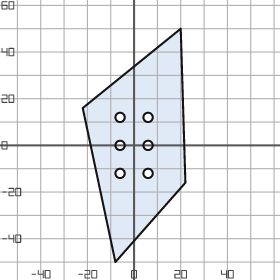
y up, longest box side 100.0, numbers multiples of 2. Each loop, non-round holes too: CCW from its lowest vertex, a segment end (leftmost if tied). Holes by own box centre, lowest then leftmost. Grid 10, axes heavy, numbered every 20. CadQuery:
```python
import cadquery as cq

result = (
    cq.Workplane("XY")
    .moveTo(-8.0, -50.0)
    .lineTo(22.0, -16.0)
    .lineTo(20.0, 50.0)
    .lineTo(-22.0, 16.0)
    .close()
    .moveTo(-6.0, -12.0)
    .circle(2.0)
    .moveTo(6.0, -12.0)
    .circle(2.0)
    .moveTo(-6.0, 0.0)
    .circle(2.0)
    .moveTo(6.0, 0.0)
    .circle(2.0)
    .moveTo(-6.0, 12.0)
    .circle(2.0)
    .moveTo(6.0, 12.0)
    .circle(2.0)
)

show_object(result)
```